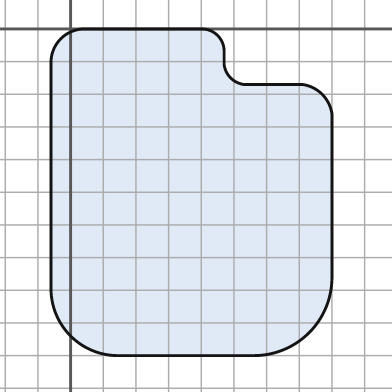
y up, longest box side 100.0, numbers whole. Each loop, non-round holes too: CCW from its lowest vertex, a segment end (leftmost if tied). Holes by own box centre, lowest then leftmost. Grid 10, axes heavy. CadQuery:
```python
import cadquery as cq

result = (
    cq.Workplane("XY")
    .moveTo(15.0, -100.0)
    .lineTo(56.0, -100.0)
    .threePointArc((73.0, -93.0), (80.0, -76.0))
    .lineTo(80.0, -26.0)
    .threePointArc((77.0, -20.0), (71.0, -17.0))
    .lineTo(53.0, -17.0)
    .threePointArc((49.0, -15.0), (47.0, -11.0))
    .lineTo(47.0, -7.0)
    .threePointArc((45.0, -2.0), (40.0, 0.0))
    .lineTo(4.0, 0.0)
    .threePointArc((-3.0, -3.0), (-6.0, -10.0))
    .lineTo(-6.0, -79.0)
    .threePointArc((0.0, -94.0), (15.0, -100.0))
    .close()
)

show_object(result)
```